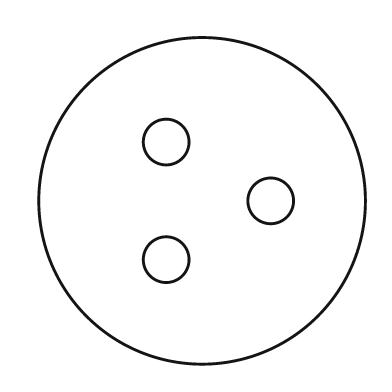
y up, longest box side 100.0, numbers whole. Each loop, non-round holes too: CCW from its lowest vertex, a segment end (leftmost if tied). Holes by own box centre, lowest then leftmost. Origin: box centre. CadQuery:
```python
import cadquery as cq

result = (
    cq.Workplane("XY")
    .moveTo(0.0, 0.0)
    .circle(50.0)
    .moveTo(-11.0, -18.0)
    .circle(7.0)
    .moveTo(21.0, 0.0)
    .circle(7.0)
    .moveTo(-11.0, 18.0)
    .circle(7.0)
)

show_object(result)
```